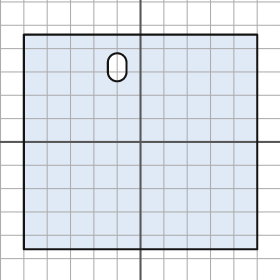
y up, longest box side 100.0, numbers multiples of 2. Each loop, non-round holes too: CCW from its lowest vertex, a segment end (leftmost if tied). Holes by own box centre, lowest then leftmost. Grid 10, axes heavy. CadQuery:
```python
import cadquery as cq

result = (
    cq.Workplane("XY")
    .moveTo(-50.0, -46.0)
    .lineTo(50.0, -46.0)
    .lineTo(50.0, 46.0)
    .lineTo(-50.0, 46.0)
    .close()
    .moveTo(-14.0, 30.0)
    .threePointArc((-10.0, 26.0), (-6.0, 30.0))
    .lineTo(-6.0, 34.0)
    .threePointArc((-10.0, 38.0), (-14.0, 34.0))
    .close()
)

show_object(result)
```